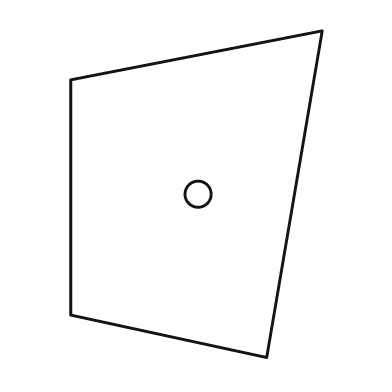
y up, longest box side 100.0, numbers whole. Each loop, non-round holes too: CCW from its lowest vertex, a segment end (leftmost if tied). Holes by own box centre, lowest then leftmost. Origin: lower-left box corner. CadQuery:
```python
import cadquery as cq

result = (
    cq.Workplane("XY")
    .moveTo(60.0, 0.0)
    .lineTo(77.0, 100.0)
    .lineTo(0.0, 85.0)
    .lineTo(0.0, 13.0)
    .close()
    .moveTo(39.0, 50.0)
    .circle(4.0)
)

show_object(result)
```